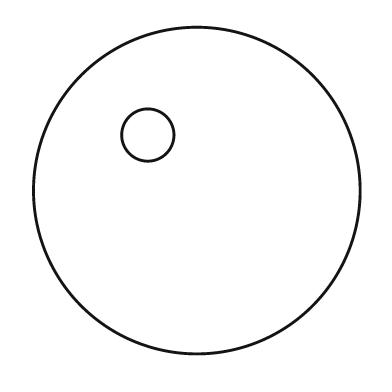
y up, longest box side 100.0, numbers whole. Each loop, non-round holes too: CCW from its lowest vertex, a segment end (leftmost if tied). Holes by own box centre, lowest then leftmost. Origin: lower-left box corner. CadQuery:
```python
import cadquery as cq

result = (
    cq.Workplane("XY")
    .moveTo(50.0, 50.0)
    .circle(50.0)
    .moveTo(35.0, 67.0)
    .circle(8.0)
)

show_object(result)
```